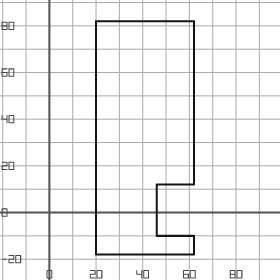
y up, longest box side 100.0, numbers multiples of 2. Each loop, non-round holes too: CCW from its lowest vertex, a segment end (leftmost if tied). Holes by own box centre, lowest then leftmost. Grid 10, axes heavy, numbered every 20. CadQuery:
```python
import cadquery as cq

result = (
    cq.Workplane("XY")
    .moveTo(20.0, -18.0)
    .lineTo(62.0, -18.0)
    .lineTo(62.0, -10.0)
    .lineTo(46.0, -10.0)
    .lineTo(46.0, 12.0)
    .lineTo(62.0, 12.0)
    .lineTo(62.0, 82.0)
    .lineTo(20.0, 82.0)
    .close()
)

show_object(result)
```